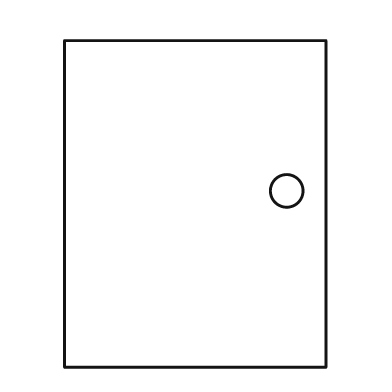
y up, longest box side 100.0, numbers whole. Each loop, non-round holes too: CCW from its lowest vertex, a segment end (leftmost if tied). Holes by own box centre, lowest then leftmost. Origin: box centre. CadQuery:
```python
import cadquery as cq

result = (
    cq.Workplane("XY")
    .moveTo(-40.0, -50.0)
    .lineTo(40.0, -50.0)
    .lineTo(40.0, 50.0)
    .lineTo(-40.0, 50.0)
    .close()
    .moveTo(28.0, 4.0)
    .circle(5.0)
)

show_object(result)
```